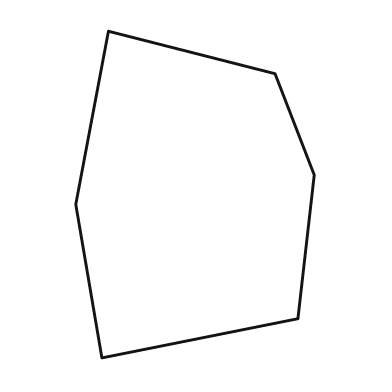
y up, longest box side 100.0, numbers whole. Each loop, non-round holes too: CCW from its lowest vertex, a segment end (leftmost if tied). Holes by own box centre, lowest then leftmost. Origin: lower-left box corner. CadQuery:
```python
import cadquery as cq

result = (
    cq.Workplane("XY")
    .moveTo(8.0, 0.0)
    .lineTo(68.0, 12.0)
    .lineTo(73.0, 56.0)
    .lineTo(61.0, 87.0)
    .lineTo(10.0, 100.0)
    .lineTo(0.0, 47.0)
    .close()
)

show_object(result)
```